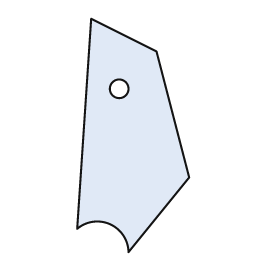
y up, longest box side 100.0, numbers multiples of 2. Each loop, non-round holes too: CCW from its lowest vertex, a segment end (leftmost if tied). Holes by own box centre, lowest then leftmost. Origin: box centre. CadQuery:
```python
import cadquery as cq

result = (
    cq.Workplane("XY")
    .moveTo(-2.0, -50.0)
    .lineTo(24.0, -18.0)
    .lineTo(10.0, 36.0)
    .lineTo(-18.0, 50.0)
    .lineTo(-24.0, -40.0)
    .threePointArc((-10.0, -38.0), (-2.0, -50.0))
    .close()
    .moveTo(-6.0, 20.0)
    .circle(4.0)
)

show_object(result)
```